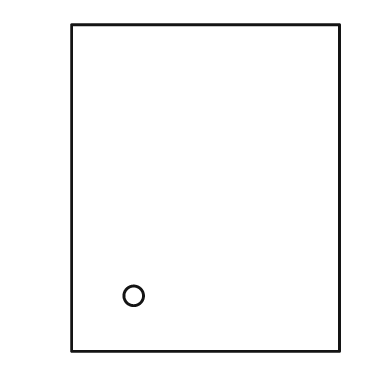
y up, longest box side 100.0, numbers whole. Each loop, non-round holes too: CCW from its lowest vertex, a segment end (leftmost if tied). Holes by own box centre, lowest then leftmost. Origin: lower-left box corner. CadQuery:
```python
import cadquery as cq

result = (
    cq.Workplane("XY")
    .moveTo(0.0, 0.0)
    .lineTo(82.0, 0.0)
    .lineTo(82.0, 100.0)
    .lineTo(0.0, 100.0)
    .close()
    .moveTo(19.0, 17.0)
    .circle(3.0)
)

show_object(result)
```